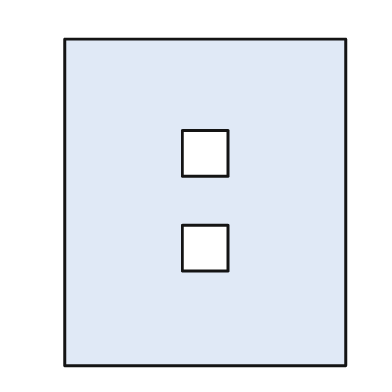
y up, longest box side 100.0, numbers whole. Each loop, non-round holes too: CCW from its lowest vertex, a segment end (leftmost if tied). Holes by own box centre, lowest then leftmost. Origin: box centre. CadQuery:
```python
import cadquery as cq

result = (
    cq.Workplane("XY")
    .moveTo(-43.0, -50.0)
    .lineTo(43.0, -50.0)
    .lineTo(43.0, 50.0)
    .lineTo(-43.0, 50.0)
    .close()
    .moveTo(-7.0, -21.0)
    .lineTo(7.0, -21.0)
    .lineTo(7.0, -7.0)
    .lineTo(-7.0, -7.0)
    .close()
    .moveTo(-7.0, 8.0)
    .lineTo(7.0, 8.0)
    .lineTo(7.0, 22.0)
    .lineTo(-7.0, 22.0)
    .close()
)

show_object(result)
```